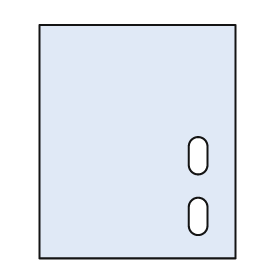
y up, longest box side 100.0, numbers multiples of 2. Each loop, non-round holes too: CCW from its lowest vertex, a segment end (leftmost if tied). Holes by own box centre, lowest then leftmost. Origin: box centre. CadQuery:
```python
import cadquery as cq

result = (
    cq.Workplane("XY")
    .moveTo(-42.0, -50.0)
    .lineTo(42.0, -50.0)
    .lineTo(42.0, 50.0)
    .lineTo(-42.0, 50.0)
    .close()
    .moveTo(22.0, -36.0)
    .threePointArc((26.0, -40.0), (30.0, -36.0))
    .lineTo(30.0, -28.0)
    .threePointArc((26.0, -24.0), (22.0, -28.0))
    .close()
    .moveTo(22.0, -10.0)
    .threePointArc((26.0, -14.0), (30.0, -10.0))
    .lineTo(30.0, -2.0)
    .threePointArc((26.0, 2.0), (22.0, -2.0))
    .close()
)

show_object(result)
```